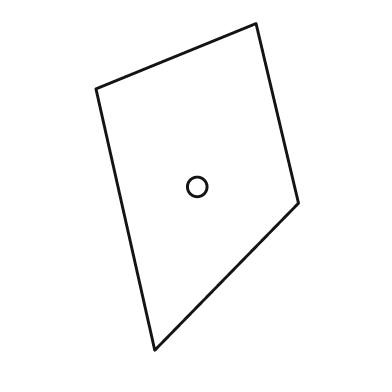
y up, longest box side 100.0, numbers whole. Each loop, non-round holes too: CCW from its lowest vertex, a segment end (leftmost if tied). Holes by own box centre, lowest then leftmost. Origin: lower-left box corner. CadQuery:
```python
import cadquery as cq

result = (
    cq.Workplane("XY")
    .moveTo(18.0, 0.0)
    .lineTo(62.0, 45.0)
    .lineTo(49.0, 100.0)
    .lineTo(0.0, 80.0)
    .close()
    .moveTo(31.0, 50.0)
    .circle(3.0)
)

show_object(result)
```